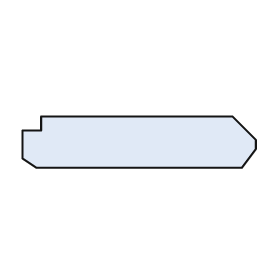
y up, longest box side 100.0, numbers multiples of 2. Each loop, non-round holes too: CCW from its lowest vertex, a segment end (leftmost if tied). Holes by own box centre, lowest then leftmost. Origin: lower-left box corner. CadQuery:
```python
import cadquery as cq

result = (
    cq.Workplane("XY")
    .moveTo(6.0, 0.0)
    .lineTo(94.0, 0.0)
    .lineTo(100.0, 8.0)
    .lineTo(100.0, 12.0)
    .lineTo(90.0, 22.0)
    .lineTo(8.0, 22.0)
    .lineTo(8.0, 16.0)
    .lineTo(0.0, 16.0)
    .lineTo(0.0, 4.0)
    .close()
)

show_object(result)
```